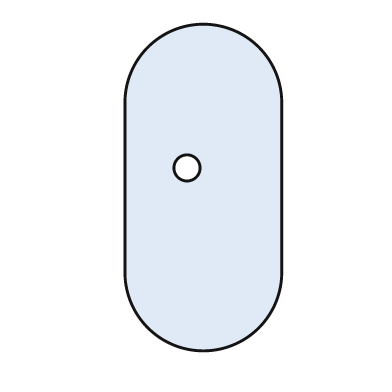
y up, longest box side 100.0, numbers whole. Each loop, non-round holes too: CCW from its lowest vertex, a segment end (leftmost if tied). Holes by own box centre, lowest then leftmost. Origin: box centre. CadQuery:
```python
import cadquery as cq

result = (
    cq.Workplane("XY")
    .moveTo(-24.0, -26.0)
    .threePointArc((0.0, -50.0), (24.0, -26.0))
    .lineTo(24.0, 26.0)
    .threePointArc((0.0, 50.0), (-24.0, 26.0))
    .close()
    .moveTo(-5.0, 6.0)
    .circle(4.0)
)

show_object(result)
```